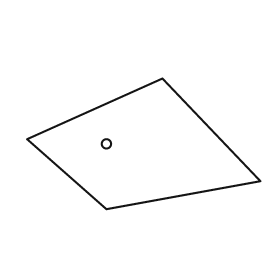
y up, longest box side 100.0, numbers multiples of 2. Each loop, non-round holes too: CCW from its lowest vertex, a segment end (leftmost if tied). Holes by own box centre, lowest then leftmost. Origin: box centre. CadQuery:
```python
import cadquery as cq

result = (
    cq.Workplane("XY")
    .moveTo(-16.0, -28.0)
    .lineTo(50.0, -16.0)
    .lineTo(8.0, 28.0)
    .lineTo(-50.0, 2.0)
    .close()
    .moveTo(-16.0, 0.0)
    .circle(2.0)
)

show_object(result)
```